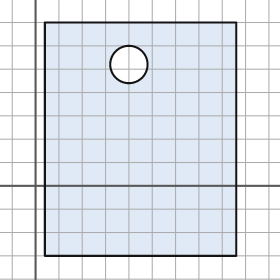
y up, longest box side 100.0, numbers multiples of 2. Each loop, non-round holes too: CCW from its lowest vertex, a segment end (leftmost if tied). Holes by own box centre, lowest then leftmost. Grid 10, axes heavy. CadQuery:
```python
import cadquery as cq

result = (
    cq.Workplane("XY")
    .moveTo(4.0, -30.0)
    .lineTo(86.0, -30.0)
    .lineTo(86.0, 70.0)
    .lineTo(4.0, 70.0)
    .close()
    .moveTo(40.0, 52.0)
    .circle(8.0)
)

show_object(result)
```